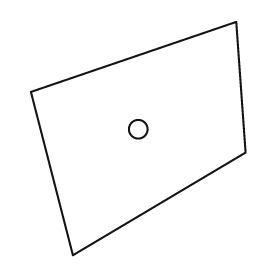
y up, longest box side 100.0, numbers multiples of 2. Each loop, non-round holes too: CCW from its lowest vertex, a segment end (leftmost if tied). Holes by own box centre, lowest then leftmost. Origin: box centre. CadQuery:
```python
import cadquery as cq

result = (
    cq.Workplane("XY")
    .moveTo(-28.0, -50.0)
    .lineTo(46.0, -6.0)
    .lineTo(42.0, 50.0)
    .lineTo(-46.0, 20.0)
    .close()
    .moveTo(0.0, 4.0)
    .circle(4.0)
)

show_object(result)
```